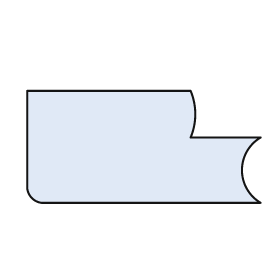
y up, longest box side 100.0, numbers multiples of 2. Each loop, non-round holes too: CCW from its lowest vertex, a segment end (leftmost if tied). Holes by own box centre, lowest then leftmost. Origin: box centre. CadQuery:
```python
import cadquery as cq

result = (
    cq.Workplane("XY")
    .moveTo(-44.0, -24.0)
    .lineTo(50.0, -24.0)
    .threePointArc((42.0, -10.0), (50.0, 4.0))
    .lineTo(20.0, 4.0)
    .threePointArc((22.0, 14.0), (20.0, 24.0))
    .lineTo(-50.0, 24.0)
    .lineTo(-50.0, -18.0)
    .threePointArc((-48.0, -22.0), (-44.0, -24.0))
    .close()
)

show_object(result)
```